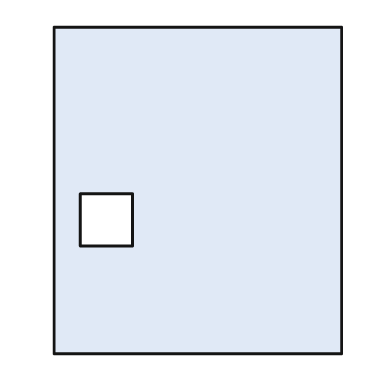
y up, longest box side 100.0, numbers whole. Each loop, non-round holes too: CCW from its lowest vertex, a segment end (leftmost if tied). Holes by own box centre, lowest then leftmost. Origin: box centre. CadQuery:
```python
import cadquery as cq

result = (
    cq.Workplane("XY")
    .moveTo(-44.0, -50.0)
    .lineTo(44.0, -50.0)
    .lineTo(44.0, 50.0)
    .lineTo(-44.0, 50.0)
    .close()
    .moveTo(-36.0, -17.0)
    .lineTo(-20.0, -17.0)
    .lineTo(-20.0, -1.0)
    .lineTo(-36.0, -1.0)
    .close()
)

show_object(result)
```